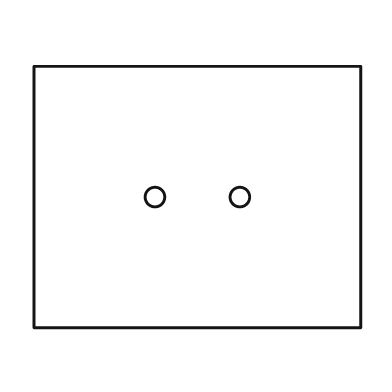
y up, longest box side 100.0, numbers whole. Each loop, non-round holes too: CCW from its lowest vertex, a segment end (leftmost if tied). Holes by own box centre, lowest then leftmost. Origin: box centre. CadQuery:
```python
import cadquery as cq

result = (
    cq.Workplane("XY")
    .moveTo(-50.0, -40.0)
    .lineTo(50.0, -40.0)
    .lineTo(50.0, 40.0)
    .lineTo(-50.0, 40.0)
    .close()
    .moveTo(-13.0, 0.0)
    .circle(3.0)
    .moveTo(13.0, 0.0)
    .circle(3.0)
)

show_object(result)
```